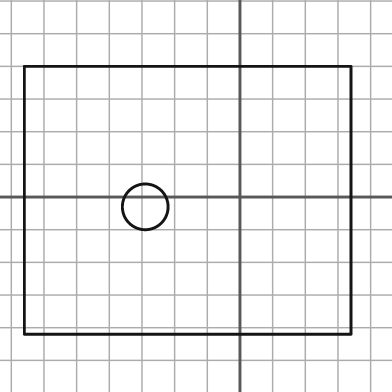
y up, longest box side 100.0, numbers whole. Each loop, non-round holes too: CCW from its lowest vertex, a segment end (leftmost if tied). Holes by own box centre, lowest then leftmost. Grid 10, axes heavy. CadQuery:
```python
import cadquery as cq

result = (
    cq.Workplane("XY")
    .moveTo(-66.0, -42.0)
    .lineTo(34.0, -42.0)
    .lineTo(34.0, 40.0)
    .lineTo(-66.0, 40.0)
    .close()
    .moveTo(-29.0, -3.0)
    .circle(7.0)
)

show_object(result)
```